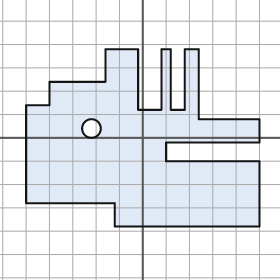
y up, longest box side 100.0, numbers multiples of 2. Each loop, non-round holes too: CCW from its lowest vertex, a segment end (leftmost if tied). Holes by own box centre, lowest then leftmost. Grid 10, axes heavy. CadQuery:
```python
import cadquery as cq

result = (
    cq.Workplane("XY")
    .moveTo(-12.0, -38.0)
    .lineTo(50.0, -38.0)
    .lineTo(50.0, -10.0)
    .lineTo(10.0, -10.0)
    .lineTo(10.0, -2.0)
    .lineTo(50.0, -2.0)
    .lineTo(50.0, 8.0)
    .lineTo(24.0, 8.0)
    .lineTo(24.0, 38.0)
    .lineTo(18.0, 38.0)
    .lineTo(18.0, 12.0)
    .lineTo(12.0, 12.0)
    .lineTo(12.0, 38.0)
    .lineTo(8.0, 38.0)
    .lineTo(8.0, 12.0)
    .lineTo(-2.0, 12.0)
    .lineTo(-2.0, 38.0)
    .lineTo(-16.0, 38.0)
    .lineTo(-16.0, 24.0)
    .lineTo(-40.0, 24.0)
    .lineTo(-40.0, 14.0)
    .lineTo(-50.0, 14.0)
    .lineTo(-50.0, -28.0)
    .lineTo(-12.0, -28.0)
    .close()
    .moveTo(-22.0, 4.0)
    .circle(4.0)
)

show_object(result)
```